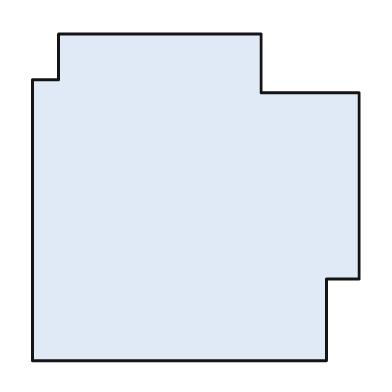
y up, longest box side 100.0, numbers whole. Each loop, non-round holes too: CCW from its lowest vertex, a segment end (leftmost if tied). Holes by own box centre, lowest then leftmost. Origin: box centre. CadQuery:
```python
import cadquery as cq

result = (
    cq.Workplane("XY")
    .moveTo(-50.0, -50.0)
    .lineTo(40.0, -50.0)
    .lineTo(40.0, -25.0)
    .lineTo(50.0, -25.0)
    .lineTo(50.0, 32.0)
    .lineTo(20.0, 32.0)
    .lineTo(20.0, 50.0)
    .lineTo(-42.0, 50.0)
    .lineTo(-42.0, 36.0)
    .lineTo(-50.0, 36.0)
    .close()
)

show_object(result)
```